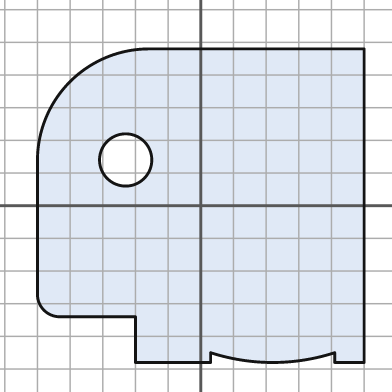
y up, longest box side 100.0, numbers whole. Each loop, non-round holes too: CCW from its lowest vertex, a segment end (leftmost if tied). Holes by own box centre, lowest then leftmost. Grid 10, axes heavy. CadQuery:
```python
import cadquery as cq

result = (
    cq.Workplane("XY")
    .moveTo(-20.0, -48.0)
    .lineTo(3.0, -48.0)
    .lineTo(3.0, -45.0)
    .threePointArc((22.0, -48.0), (41.0, -45.0))
    .lineTo(41.0, -48.0)
    .lineTo(50.0, -48.0)
    .lineTo(50.0, 48.0)
    .lineTo(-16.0, 48.0)
    .threePointArc((-40.0, 38.0), (-50.0, 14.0))
    .lineTo(-50.0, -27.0)
    .threePointArc((-48.0, -32.0), (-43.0, -34.0))
    .lineTo(-20.0, -34.0)
    .close()
    .moveTo(-23.0, 14.0)
    .circle(8.0)
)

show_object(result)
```